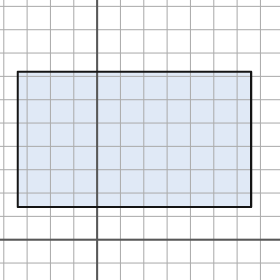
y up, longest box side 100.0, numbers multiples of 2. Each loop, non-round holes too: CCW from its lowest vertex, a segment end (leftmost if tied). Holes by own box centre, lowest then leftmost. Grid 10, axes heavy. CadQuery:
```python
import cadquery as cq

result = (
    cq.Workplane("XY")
    .moveTo(-34.0, 14.0)
    .lineTo(66.0, 14.0)
    .lineTo(66.0, 72.0)
    .lineTo(-34.0, 72.0)
    .close()
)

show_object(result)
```